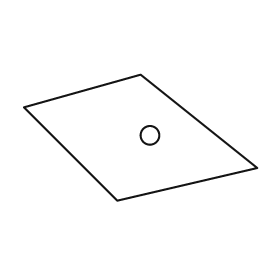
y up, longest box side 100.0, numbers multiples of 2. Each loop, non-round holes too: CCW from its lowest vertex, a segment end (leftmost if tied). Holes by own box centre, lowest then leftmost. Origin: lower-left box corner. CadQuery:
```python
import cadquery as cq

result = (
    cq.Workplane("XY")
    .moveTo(40.0, 0.0)
    .lineTo(100.0, 14.0)
    .lineTo(50.0, 54.0)
    .lineTo(0.0, 40.0)
    .close()
    .moveTo(54.0, 28.0)
    .circle(4.0)
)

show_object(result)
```